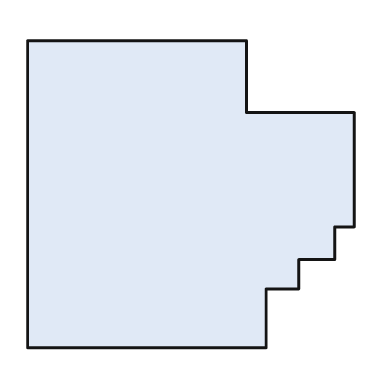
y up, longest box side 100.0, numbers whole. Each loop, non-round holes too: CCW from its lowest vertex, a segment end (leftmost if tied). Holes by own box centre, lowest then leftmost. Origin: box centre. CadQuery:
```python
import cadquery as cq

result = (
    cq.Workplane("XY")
    .moveTo(-50.0, -47.0)
    .lineTo(23.0, -47.0)
    .lineTo(23.0, -29.0)
    .lineTo(33.0, -29.0)
    .lineTo(33.0, -20.0)
    .lineTo(44.0, -20.0)
    .lineTo(44.0, -10.0)
    .lineTo(50.0, -10.0)
    .lineTo(50.0, 25.0)
    .lineTo(17.0, 25.0)
    .lineTo(17.0, 47.0)
    .lineTo(-50.0, 47.0)
    .close()
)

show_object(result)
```